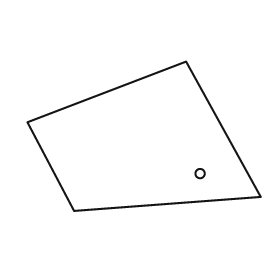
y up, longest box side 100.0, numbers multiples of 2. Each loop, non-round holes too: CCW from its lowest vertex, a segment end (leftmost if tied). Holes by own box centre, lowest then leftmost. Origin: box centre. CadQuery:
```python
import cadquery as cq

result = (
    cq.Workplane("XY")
    .moveTo(-30.0, -32.0)
    .lineTo(50.0, -26.0)
    .lineTo(18.0, 32.0)
    .lineTo(-50.0, 6.0)
    .close()
    .moveTo(24.0, -16.0)
    .circle(2.0)
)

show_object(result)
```